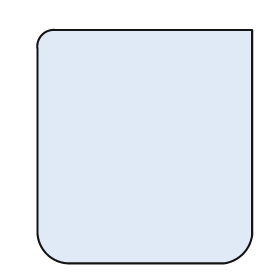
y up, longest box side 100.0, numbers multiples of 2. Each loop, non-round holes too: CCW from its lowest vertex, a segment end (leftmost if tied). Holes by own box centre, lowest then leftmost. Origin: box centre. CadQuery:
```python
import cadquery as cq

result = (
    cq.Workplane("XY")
    .moveTo(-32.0, -50.0)
    .lineTo(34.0, -50.0)
    .threePointArc((42.0, -46.0), (46.0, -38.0))
    .lineTo(46.0, 50.0)
    .lineTo(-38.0, 50.0)
    .threePointArc((-44.0, 48.0), (-46.0, 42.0))
    .lineTo(-46.0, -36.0)
    .threePointArc((-42.0, -46.0), (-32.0, -50.0))
    .close()
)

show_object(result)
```